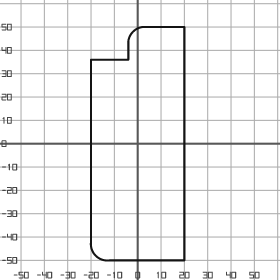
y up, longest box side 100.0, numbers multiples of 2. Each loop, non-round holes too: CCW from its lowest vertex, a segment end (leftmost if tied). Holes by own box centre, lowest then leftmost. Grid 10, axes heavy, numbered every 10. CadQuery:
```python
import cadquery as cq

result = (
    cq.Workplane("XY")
    .moveTo(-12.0, -50.0)
    .lineTo(20.0, -50.0)
    .lineTo(20.0, 50.0)
    .lineTo(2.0, 50.0)
    .threePointArc((-2.0, 48.0), (-4.0, 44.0))
    .lineTo(-4.0, 36.0)
    .lineTo(-20.0, 36.0)
    .lineTo(-20.0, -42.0)
    .threePointArc((-18.0, -48.0), (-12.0, -50.0))
    .close()
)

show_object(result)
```